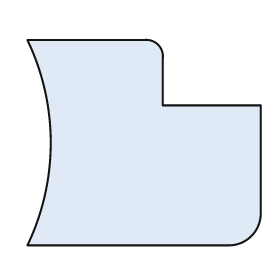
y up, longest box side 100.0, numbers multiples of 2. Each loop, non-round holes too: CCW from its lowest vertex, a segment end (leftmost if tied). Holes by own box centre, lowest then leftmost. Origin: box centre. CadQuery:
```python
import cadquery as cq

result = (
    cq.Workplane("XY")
    .moveTo(-50.0, -44.0)
    .lineTo(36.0, -44.0)
    .threePointArc((46.0, -40.0), (50.0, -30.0))
    .lineTo(50.0, 16.0)
    .lineTo(8.0, 16.0)
    .lineTo(8.0, 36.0)
    .threePointArc((6.0, 42.0), (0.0, 44.0))
    .lineTo(-50.0, 44.0)
    .threePointArc((-40.0, 0.0), (-50.0, -44.0))
    .close()
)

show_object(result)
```